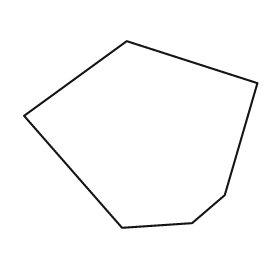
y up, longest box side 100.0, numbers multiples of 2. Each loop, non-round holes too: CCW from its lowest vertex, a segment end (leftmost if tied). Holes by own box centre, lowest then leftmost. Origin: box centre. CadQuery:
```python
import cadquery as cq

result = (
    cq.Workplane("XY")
    .moveTo(-8.0, -40.0)
    .lineTo(22.0, -38.0)
    .lineTo(36.0, -26.0)
    .lineTo(50.0, 22.0)
    .lineTo(-6.0, 40.0)
    .lineTo(-50.0, 8.0)
    .close()
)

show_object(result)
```